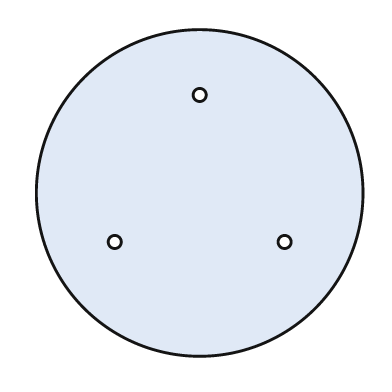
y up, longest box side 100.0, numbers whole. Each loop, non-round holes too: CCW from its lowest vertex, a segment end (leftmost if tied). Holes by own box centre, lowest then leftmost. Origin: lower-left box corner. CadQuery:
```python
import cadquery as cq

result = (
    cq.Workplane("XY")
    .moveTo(50.0, 50.0)
    .circle(50.0)
    .moveTo(24.0, 35.0)
    .circle(2.0)
    .moveTo(76.0, 35.0)
    .circle(2.0)
    .moveTo(50.0, 80.0)
    .circle(2.0)
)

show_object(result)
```